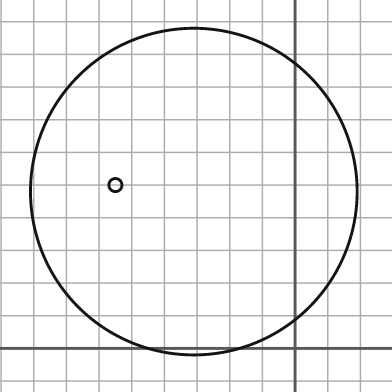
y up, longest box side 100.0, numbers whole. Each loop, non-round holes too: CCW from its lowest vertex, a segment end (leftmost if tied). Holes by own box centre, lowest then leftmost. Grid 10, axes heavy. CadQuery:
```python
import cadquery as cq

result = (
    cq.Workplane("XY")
    .moveTo(-31.0, 48.0)
    .circle(50.0)
    .moveTo(-55.0, 50.0)
    .circle(2.0)
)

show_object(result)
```